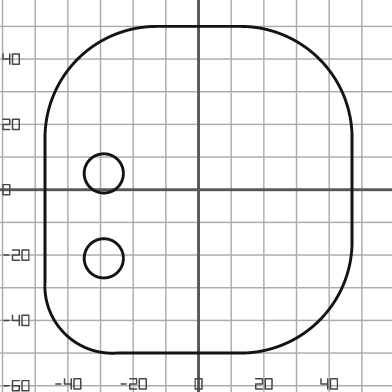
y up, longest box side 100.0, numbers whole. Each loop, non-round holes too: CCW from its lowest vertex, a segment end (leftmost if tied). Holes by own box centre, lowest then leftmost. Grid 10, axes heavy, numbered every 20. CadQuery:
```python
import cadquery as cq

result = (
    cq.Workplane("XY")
    .moveTo(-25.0, -50.0)
    .lineTo(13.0, -50.0)
    .threePointArc((37.0, -40.0), (47.0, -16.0))
    .lineTo(47.0, 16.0)
    .threePointArc((37.0, 40.0), (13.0, 50.0))
    .lineTo(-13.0, 50.0)
    .threePointArc((-37.0, 40.0), (-47.0, 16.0))
    .lineTo(-47.0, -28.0)
    .threePointArc((-41.0, -44.0), (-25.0, -50.0))
    .close()
    .moveTo(-29.0, -21.0)
    .circle(6.0)
    .moveTo(-29.0, 5.0)
    .circle(6.0)
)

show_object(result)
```